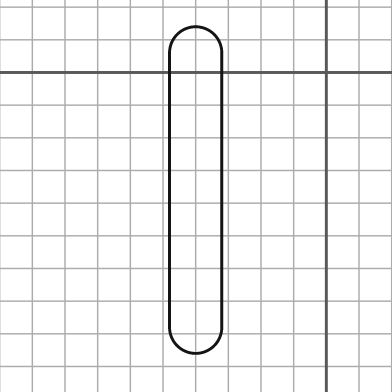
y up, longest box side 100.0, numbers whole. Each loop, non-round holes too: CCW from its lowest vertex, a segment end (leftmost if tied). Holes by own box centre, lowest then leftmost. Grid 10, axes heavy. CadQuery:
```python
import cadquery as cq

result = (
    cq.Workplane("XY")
    .moveTo(-48.0, -78.0)
    .threePointArc((-40.0, -86.0), (-32.0, -78.0))
    .lineTo(-32.0, 6.0)
    .threePointArc((-40.0, 14.0), (-48.0, 6.0))
    .close()
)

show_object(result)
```